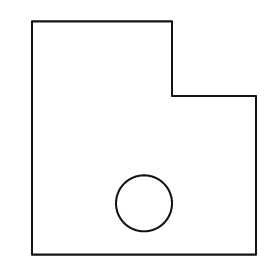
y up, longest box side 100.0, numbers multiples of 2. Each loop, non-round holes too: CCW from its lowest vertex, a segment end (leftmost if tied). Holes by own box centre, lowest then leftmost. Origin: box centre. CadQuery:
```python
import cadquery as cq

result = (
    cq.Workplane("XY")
    .moveTo(-48.0, -50.0)
    .lineTo(48.0, -50.0)
    .lineTo(48.0, 18.0)
    .lineTo(12.0, 18.0)
    .lineTo(12.0, 50.0)
    .lineTo(-48.0, 50.0)
    .close()
    .moveTo(0.0, -28.0)
    .circle(12.0)
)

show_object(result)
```